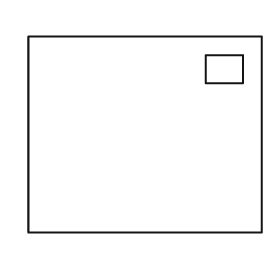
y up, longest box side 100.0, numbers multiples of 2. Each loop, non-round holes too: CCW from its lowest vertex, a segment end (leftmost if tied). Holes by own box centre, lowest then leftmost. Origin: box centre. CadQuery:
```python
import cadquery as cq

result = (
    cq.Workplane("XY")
    .moveTo(-50.0, -42.0)
    .lineTo(50.0, -42.0)
    .lineTo(50.0, 42.0)
    .lineTo(-50.0, 42.0)
    .close()
    .moveTo(26.0, 22.0)
    .lineTo(42.0, 22.0)
    .lineTo(42.0, 34.0)
    .lineTo(26.0, 34.0)
    .close()
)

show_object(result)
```